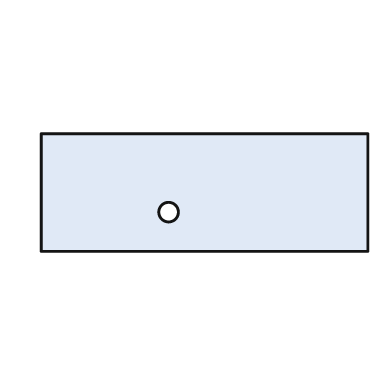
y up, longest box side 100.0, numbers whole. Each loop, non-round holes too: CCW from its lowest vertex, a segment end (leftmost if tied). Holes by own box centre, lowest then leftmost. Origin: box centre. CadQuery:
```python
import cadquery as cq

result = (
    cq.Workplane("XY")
    .moveTo(-50.0, -18.0)
    .lineTo(50.0, -18.0)
    .lineTo(50.0, 18.0)
    .lineTo(-50.0, 18.0)
    .close()
    .moveTo(-11.0, -6.0)
    .circle(3.0)
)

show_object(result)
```